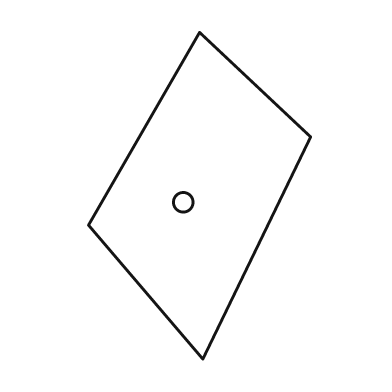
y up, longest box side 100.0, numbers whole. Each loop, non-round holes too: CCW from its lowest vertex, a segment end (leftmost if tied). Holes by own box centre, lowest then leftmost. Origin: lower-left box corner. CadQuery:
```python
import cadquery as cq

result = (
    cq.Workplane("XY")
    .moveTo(35.0, 0.0)
    .lineTo(68.0, 68.0)
    .lineTo(34.0, 100.0)
    .lineTo(0.0, 41.0)
    .close()
    .moveTo(29.0, 48.0)
    .circle(3.0)
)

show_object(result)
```